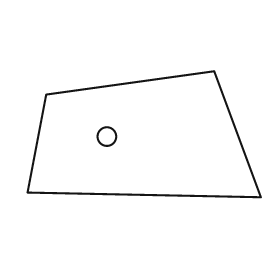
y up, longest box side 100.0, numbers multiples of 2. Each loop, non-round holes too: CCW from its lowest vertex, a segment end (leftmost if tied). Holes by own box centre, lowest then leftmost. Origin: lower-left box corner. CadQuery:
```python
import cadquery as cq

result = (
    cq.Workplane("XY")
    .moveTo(100.0, 0.0)
    .lineTo(80.0, 54.0)
    .lineTo(8.0, 44.0)
    .lineTo(0.0, 2.0)
    .close()
    .moveTo(34.0, 26.0)
    .circle(4.0)
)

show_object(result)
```